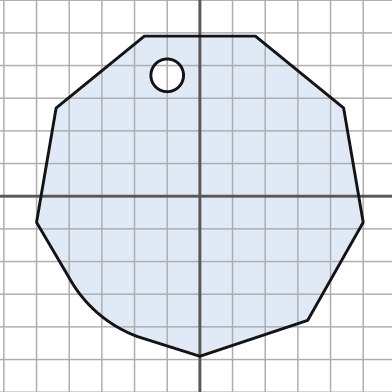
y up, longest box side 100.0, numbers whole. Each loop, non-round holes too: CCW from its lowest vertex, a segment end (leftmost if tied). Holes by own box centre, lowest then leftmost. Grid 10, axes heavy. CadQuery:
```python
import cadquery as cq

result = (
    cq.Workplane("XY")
    .moveTo(0.0, -49.0)
    .lineTo(33.0, -38.0)
    .lineTo(50.0, -8.0)
    .lineTo(44.0, 27.0)
    .lineTo(17.0, 49.0)
    .lineTo(-17.0, 49.0)
    .lineTo(-44.0, 27.0)
    .lineTo(-50.0, -8.0)
    .lineTo(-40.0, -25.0)
    .threePointArc((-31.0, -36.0), (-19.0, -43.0))
    .close()
    .moveTo(-10.0, 37.0)
    .circle(5.0)
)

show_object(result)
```